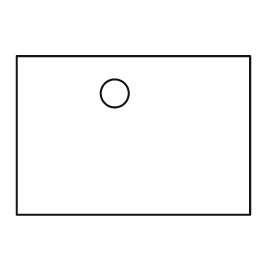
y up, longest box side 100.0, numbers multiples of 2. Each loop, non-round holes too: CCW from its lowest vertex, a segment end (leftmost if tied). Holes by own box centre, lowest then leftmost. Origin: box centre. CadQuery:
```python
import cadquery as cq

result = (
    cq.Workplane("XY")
    .moveTo(-50.0, -34.0)
    .lineTo(50.0, -34.0)
    .lineTo(50.0, 34.0)
    .lineTo(-50.0, 34.0)
    .close()
    .moveTo(-8.0, 18.0)
    .circle(6.0)
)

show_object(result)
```